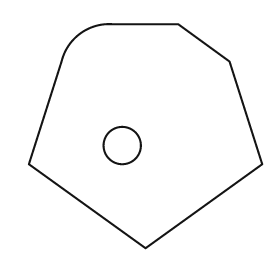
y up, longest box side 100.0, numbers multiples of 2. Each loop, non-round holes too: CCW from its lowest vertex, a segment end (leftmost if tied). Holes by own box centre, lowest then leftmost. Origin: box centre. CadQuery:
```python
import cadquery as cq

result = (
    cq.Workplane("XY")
    .moveTo(0.0, -48.0)
    .lineTo(50.0, -12.0)
    .lineTo(36.0, 32.0)
    .lineTo(14.0, 48.0)
    .lineTo(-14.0, 48.0)
    .threePointArc((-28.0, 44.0), (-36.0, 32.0))
    .lineTo(-50.0, -12.0)
    .close()
    .moveTo(-10.0, -4.0)
    .circle(8.0)
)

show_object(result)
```